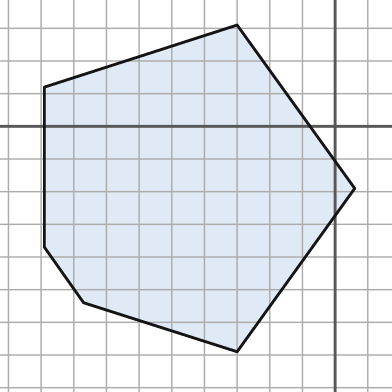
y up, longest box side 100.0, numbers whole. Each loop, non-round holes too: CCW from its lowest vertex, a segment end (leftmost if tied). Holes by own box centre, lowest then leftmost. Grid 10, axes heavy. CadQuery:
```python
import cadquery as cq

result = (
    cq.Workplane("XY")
    .moveTo(-30.0, -69.0)
    .lineTo(6.0, -19.0)
    .lineTo(-30.0, 31.0)
    .lineTo(-89.0, 12.0)
    .lineTo(-89.0, -37.0)
    .lineTo(-77.0, -54.0)
    .close()
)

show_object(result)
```